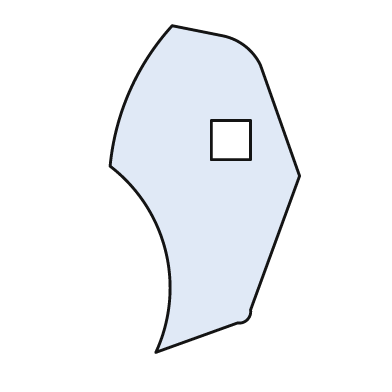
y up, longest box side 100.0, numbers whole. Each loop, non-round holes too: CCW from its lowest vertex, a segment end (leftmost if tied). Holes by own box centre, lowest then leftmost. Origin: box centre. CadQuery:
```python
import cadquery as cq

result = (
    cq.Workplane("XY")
    .moveTo(-15.0, -50.0)
    .lineTo(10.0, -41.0)
    .threePointArc((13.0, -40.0), (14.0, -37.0))
    .lineTo(29.0, 4.0)
    .lineTo(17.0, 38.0)
    .threePointArc((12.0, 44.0), (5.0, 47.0))
    .lineTo(-10.0, 50.0)
    .threePointArc((-23.0, 30.0), (-29.0, 7.0))
    .threePointArc((-12.0, -19.0), (-15.0, -50.0))
    .close()
    .moveTo(2.0, 9.0)
    .lineTo(14.0, 9.0)
    .lineTo(14.0, 21.0)
    .lineTo(2.0, 21.0)
    .close()
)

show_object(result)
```